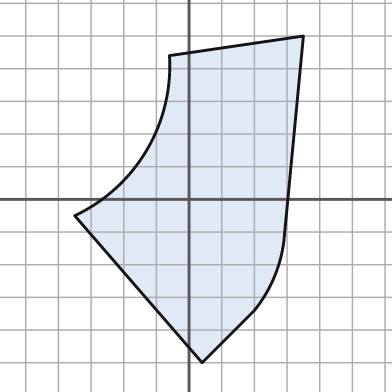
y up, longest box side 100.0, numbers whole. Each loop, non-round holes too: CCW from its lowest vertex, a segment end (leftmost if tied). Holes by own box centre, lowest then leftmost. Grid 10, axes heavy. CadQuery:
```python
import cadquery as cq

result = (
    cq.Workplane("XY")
    .moveTo(4.0, -50.0)
    .lineTo(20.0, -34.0)
    .threePointArc((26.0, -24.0), (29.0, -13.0))
    .lineTo(35.0, 50.0)
    .lineTo(-6.0, 44.0)
    .threePointArc((-13.0, 15.0), (-35.0, -5.0))
    .close()
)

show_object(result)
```